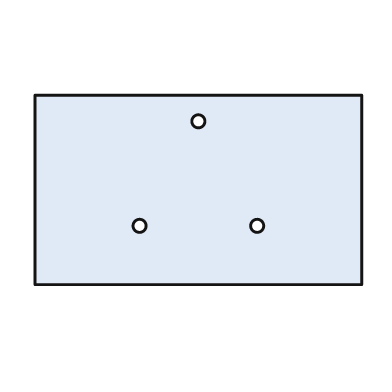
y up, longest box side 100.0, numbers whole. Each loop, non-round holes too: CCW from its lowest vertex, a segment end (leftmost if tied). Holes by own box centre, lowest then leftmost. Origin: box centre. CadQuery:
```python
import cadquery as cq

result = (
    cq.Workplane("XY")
    .moveTo(-50.0, -29.0)
    .lineTo(50.0, -29.0)
    .lineTo(50.0, 29.0)
    .lineTo(-50.0, 29.0)
    .close()
    .moveTo(-18.0, -11.0)
    .circle(2.0)
    .moveTo(18.0, -11.0)
    .circle(2.0)
    .moveTo(0.0, 21.0)
    .circle(2.0)
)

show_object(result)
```